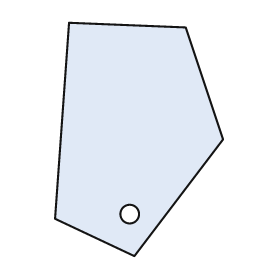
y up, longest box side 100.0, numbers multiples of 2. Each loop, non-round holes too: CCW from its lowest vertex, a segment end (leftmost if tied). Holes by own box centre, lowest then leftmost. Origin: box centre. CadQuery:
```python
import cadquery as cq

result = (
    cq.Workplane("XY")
    .moveTo(-2.0, -50.0)
    .lineTo(36.0, 0.0)
    .lineTo(20.0, 48.0)
    .lineTo(-30.0, 50.0)
    .lineTo(-36.0, -34.0)
    .close()
    .moveTo(-4.0, -32.0)
    .circle(4.0)
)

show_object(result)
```